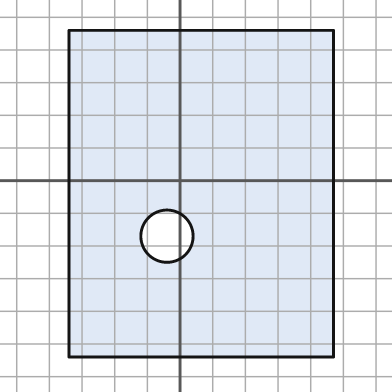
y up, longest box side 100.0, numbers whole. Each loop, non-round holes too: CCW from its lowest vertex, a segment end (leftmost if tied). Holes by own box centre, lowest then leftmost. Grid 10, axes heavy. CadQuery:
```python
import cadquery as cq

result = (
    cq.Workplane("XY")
    .moveTo(-34.0, -54.0)
    .lineTo(47.0, -54.0)
    .lineTo(47.0, 46.0)
    .lineTo(-34.0, 46.0)
    .close()
    .moveTo(-4.0, -17.0)
    .circle(8.0)
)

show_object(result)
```